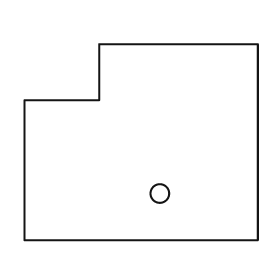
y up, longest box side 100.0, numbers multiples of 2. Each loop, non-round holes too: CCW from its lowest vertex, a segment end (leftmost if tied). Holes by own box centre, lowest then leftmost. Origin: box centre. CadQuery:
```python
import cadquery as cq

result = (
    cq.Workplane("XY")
    .moveTo(-50.0, -42.0)
    .lineTo(50.0, -42.0)
    .lineTo(50.0, 42.0)
    .lineTo(-18.0, 42.0)
    .lineTo(-18.0, 18.0)
    .lineTo(-50.0, 18.0)
    .close()
    .moveTo(8.0, -22.0)
    .circle(4.0)
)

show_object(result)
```